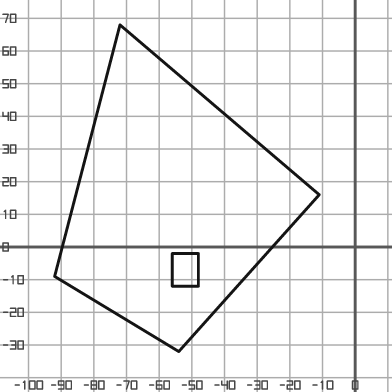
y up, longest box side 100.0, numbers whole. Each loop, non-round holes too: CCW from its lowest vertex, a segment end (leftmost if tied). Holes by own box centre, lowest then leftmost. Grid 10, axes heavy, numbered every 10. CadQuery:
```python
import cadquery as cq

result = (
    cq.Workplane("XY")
    .moveTo(-54.0, -32.0)
    .lineTo(-11.0, 16.0)
    .lineTo(-72.0, 68.0)
    .lineTo(-92.0, -9.0)
    .close()
    .moveTo(-56.0, -12.0)
    .lineTo(-48.0, -12.0)
    .lineTo(-48.0, -2.0)
    .lineTo(-56.0, -2.0)
    .close()
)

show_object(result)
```